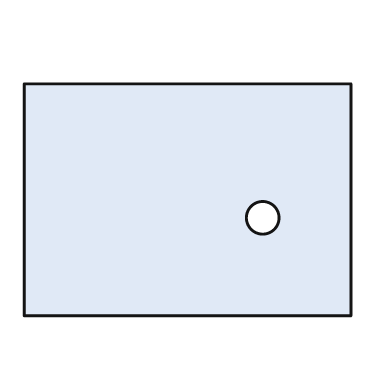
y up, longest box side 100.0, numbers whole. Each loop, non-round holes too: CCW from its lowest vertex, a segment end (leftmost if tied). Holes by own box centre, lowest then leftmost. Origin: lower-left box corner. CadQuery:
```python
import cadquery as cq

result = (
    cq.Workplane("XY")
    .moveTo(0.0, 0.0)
    .lineTo(100.0, 0.0)
    .lineTo(100.0, 71.0)
    .lineTo(0.0, 71.0)
    .close()
    .moveTo(73.0, 30.0)
    .circle(5.0)
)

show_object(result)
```